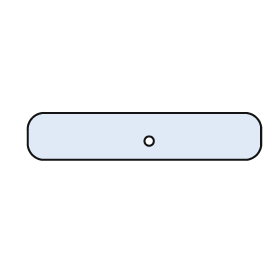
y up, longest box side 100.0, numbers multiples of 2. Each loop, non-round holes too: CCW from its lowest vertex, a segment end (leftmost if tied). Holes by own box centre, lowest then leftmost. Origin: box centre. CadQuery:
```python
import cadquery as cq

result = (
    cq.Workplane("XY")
    .moveTo(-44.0, -10.0)
    .lineTo(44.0, -10.0)
    .threePointArc((48.0, -8.0), (50.0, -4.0))
    .lineTo(50.0, 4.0)
    .threePointArc((48.0, 8.0), (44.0, 10.0))
    .lineTo(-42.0, 10.0)
    .threePointArc((-48.0, 8.0), (-50.0, 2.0))
    .lineTo(-50.0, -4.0)
    .threePointArc((-48.0, -8.0), (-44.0, -10.0))
    .close()
    .moveTo(2.0, -2.0)
    .circle(2.0)
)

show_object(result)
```